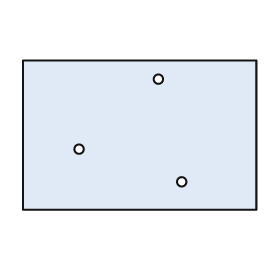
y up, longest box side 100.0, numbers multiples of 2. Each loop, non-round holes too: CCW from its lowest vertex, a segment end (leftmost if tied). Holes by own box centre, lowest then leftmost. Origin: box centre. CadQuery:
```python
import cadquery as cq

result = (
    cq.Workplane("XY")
    .moveTo(-50.0, -32.0)
    .lineTo(50.0, -32.0)
    .lineTo(50.0, 32.0)
    .lineTo(-50.0, 32.0)
    .close()
    .moveTo(18.0, -20.0)
    .circle(2.0)
    .moveTo(-26.0, -6.0)
    .circle(2.0)
    .moveTo(8.0, 24.0)
    .circle(2.0)
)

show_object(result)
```